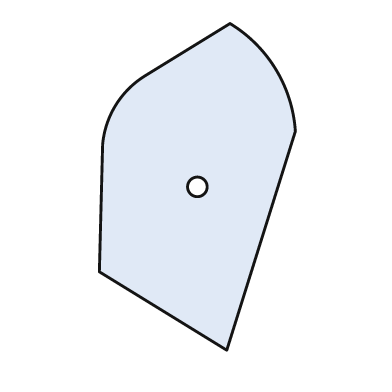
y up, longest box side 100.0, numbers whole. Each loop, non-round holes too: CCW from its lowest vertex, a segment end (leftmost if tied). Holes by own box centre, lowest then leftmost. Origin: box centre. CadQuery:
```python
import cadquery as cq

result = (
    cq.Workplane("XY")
    .moveTo(9.0, -50.0)
    .lineTo(30.0, 17.0)
    .threePointArc((24.0, 36.0), (10.0, 50.0))
    .lineTo(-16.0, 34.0)
    .threePointArc((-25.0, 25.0), (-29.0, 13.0))
    .lineTo(-30.0, -26.0)
    .close()
    .moveTo(0.0, 0.0)
    .circle(3.0)
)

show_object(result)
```